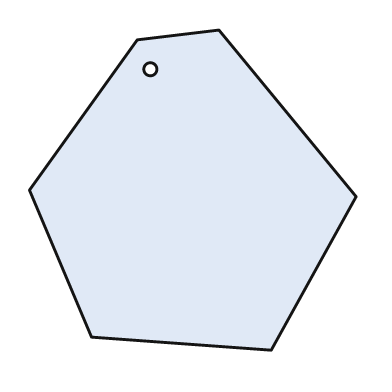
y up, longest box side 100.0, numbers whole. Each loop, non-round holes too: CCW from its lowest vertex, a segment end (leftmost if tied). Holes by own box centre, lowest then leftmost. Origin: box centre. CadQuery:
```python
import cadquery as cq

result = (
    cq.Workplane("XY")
    .moveTo(24.0, -49.0)
    .lineTo(50.0, -2.0)
    .lineTo(8.0, 49.0)
    .lineTo(-17.0, 46.0)
    .lineTo(-50.0, 0.0)
    .lineTo(-31.0, -45.0)
    .close()
    .moveTo(-13.0, 37.0)
    .circle(2.0)
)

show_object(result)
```